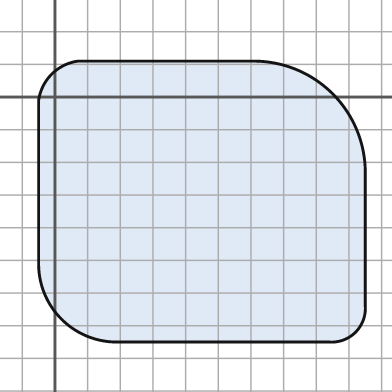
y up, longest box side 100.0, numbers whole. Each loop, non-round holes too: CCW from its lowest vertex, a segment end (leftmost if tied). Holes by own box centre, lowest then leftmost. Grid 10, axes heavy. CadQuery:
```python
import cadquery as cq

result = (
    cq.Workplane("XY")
    .moveTo(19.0, -75.0)
    .lineTo(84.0, -75.0)
    .threePointArc((92.0, -72.0), (95.0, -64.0))
    .lineTo(95.0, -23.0)
    .threePointArc((85.0, 1.0), (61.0, 11.0))
    .lineTo(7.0, 11.0)
    .threePointArc((-1.0, 7.0), (-5.0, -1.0))
    .lineTo(-5.0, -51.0)
    .threePointArc((2.0, -68.0), (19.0, -75.0))
    .close()
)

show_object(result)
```